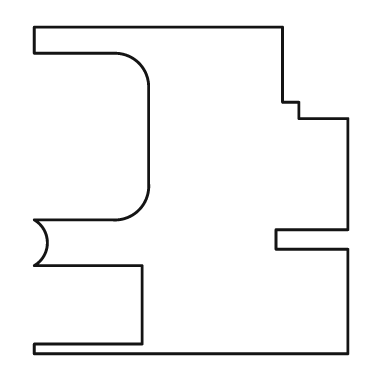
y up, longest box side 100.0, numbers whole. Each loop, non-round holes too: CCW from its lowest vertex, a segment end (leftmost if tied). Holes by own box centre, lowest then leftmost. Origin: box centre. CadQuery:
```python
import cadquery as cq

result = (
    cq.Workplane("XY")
    .moveTo(-48.0, -50.0)
    .lineTo(48.0, -50.0)
    .lineTo(48.0, -18.0)
    .lineTo(26.0, -18.0)
    .lineTo(26.0, -12.0)
    .lineTo(48.0, -12.0)
    .lineTo(48.0, 22.0)
    .lineTo(33.0, 22.0)
    .lineTo(33.0, 27.0)
    .lineTo(28.0, 27.0)
    .lineTo(28.0, 50.0)
    .lineTo(-48.0, 50.0)
    .lineTo(-48.0, 42.0)
    .lineTo(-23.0, 42.0)
    .threePointArc((-16.0, 39.0), (-13.0, 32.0))
    .lineTo(-13.0, 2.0)
    .threePointArc((-16.0, -6.0), (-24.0, -9.0))
    .lineTo(-48.0, -9.0)
    .threePointArc((-44.0, -16.0), (-48.0, -23.0))
    .lineTo(-15.0, -23.0)
    .lineTo(-15.0, -47.0)
    .lineTo(-48.0, -47.0)
    .close()
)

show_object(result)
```